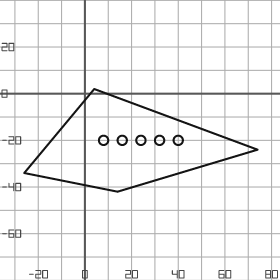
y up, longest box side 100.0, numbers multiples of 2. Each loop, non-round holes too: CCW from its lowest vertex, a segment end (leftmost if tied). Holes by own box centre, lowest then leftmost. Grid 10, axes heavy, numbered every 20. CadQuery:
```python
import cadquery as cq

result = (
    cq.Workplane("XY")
    .moveTo(14.0, -42.0)
    .lineTo(74.0, -24.0)
    .lineTo(4.0, 2.0)
    .lineTo(-26.0, -34.0)
    .close()
    .moveTo(8.0, -20.0)
    .circle(2.0)
    .moveTo(16.0, -20.0)
    .circle(2.0)
    .moveTo(24.0, -20.0)
    .circle(2.0)
    .moveTo(32.0, -20.0)
    .circle(2.0)
    .moveTo(40.0, -20.0)
    .circle(2.0)
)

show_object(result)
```